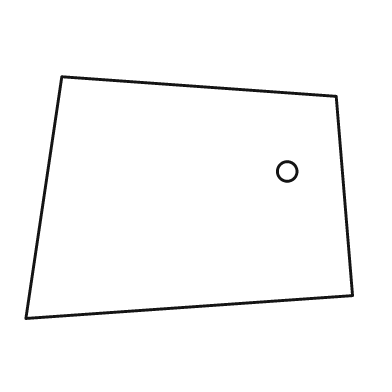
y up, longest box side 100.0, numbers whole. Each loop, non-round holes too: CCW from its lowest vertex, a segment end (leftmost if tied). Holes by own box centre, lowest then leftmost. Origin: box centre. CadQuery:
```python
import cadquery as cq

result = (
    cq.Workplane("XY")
    .moveTo(-50.0, -37.0)
    .lineTo(50.0, -30.0)
    .lineTo(45.0, 31.0)
    .lineTo(-39.0, 37.0)
    .close()
    .moveTo(30.0, 8.0)
    .circle(3.0)
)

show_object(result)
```